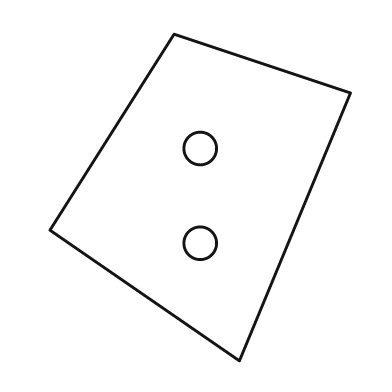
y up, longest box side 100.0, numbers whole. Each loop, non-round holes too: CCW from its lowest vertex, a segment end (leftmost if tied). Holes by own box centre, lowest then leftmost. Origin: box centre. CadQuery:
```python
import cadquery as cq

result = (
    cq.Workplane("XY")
    .moveTo(12.0, -50.0)
    .lineTo(46.0, 32.0)
    .lineTo(-8.0, 50.0)
    .lineTo(-46.0, -10.0)
    .close()
    .moveTo(0.0, -14.0)
    .circle(5.0)
    .moveTo(0.0, 15.0)
    .circle(5.0)
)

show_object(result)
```